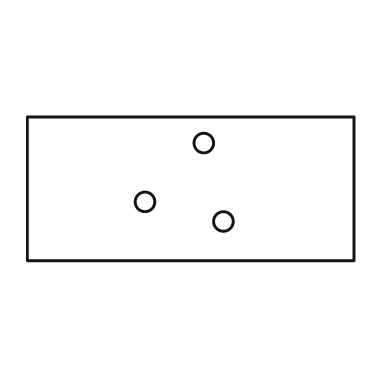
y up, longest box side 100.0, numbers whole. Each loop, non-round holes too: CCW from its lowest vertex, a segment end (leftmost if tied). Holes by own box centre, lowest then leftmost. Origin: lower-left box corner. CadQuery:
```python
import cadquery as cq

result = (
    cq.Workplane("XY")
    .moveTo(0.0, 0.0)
    .lineTo(100.0, 0.0)
    .lineTo(100.0, 44.0)
    .lineTo(0.0, 44.0)
    .close()
    .moveTo(60.0, 12.0)
    .circle(3.0)
    .moveTo(36.0, 18.0)
    .circle(3.0)
    .moveTo(54.0, 36.0)
    .circle(3.0)
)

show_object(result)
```